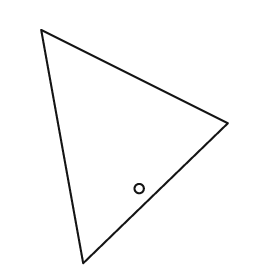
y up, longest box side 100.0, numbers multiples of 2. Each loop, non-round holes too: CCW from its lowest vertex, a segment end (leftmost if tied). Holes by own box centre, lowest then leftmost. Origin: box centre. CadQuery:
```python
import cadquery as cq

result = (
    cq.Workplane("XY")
    .moveTo(-22.0, -50.0)
    .lineTo(40.0, 10.0)
    .lineTo(-40.0, 50.0)
    .close()
    .moveTo(2.0, -18.0)
    .circle(2.0)
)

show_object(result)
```